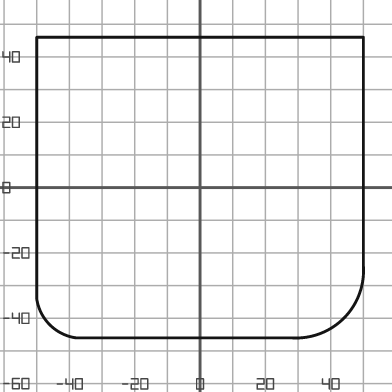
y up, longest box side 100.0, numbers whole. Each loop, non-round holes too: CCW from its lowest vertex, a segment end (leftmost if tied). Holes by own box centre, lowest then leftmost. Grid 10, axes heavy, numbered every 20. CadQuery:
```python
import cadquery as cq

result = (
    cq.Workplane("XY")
    .moveTo(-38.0, -46.0)
    .lineTo(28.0, -46.0)
    .threePointArc((44.0, -40.0), (50.0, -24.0))
    .lineTo(50.0, 46.0)
    .lineTo(-50.0, 46.0)
    .lineTo(-50.0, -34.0)
    .threePointArc((-46.0, -42.0), (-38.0, -46.0))
    .close()
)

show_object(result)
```